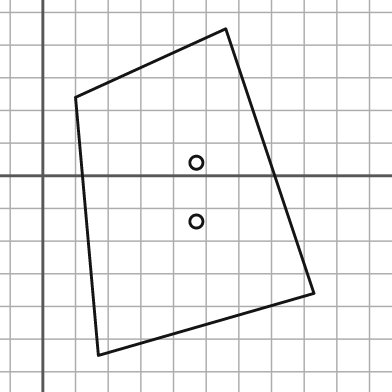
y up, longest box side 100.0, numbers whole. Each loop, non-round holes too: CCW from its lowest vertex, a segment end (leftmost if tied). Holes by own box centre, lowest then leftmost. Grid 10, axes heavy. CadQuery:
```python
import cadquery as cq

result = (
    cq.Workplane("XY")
    .moveTo(17.0, -55.0)
    .lineTo(83.0, -36.0)
    .lineTo(56.0, 45.0)
    .lineTo(10.0, 24.0)
    .close()
    .moveTo(47.0, -14.0)
    .circle(2.0)
    .moveTo(47.0, 4.0)
    .circle(2.0)
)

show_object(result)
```